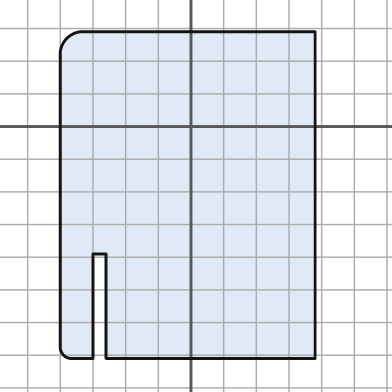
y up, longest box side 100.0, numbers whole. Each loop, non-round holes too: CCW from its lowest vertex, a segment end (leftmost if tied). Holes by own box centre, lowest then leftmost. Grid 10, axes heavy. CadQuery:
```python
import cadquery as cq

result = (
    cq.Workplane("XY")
    .moveTo(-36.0, -71.0)
    .lineTo(-30.0, -71.0)
    .lineTo(-30.0, -39.0)
    .lineTo(-26.0, -39.0)
    .lineTo(-26.0, -71.0)
    .lineTo(38.0, -71.0)
    .lineTo(38.0, 29.0)
    .lineTo(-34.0, 29.0)
    .threePointArc((-38.0, 27.0), (-40.0, 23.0))
    .lineTo(-40.0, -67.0)
    .threePointArc((-39.0, -70.0), (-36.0, -71.0))
    .close()
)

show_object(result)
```